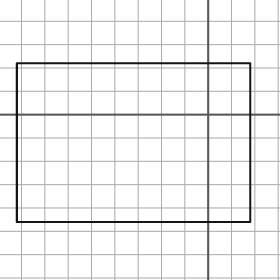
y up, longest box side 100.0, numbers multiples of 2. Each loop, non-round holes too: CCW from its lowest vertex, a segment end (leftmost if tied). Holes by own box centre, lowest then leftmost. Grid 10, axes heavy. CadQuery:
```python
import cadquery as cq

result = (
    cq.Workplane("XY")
    .moveTo(-82.0, -46.0)
    .lineTo(18.0, -46.0)
    .lineTo(18.0, 22.0)
    .lineTo(-82.0, 22.0)
    .close()
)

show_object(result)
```